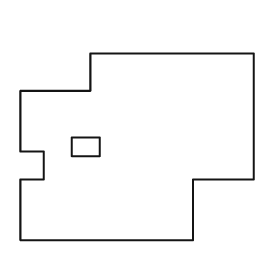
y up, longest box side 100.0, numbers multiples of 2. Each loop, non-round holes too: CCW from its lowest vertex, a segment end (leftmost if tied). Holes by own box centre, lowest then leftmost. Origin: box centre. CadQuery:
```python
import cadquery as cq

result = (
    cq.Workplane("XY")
    .moveTo(-50.0, -40.0)
    .lineTo(24.0, -40.0)
    .lineTo(24.0, -14.0)
    .lineTo(50.0, -14.0)
    .lineTo(50.0, 40.0)
    .lineTo(-20.0, 40.0)
    .lineTo(-20.0, 24.0)
    .lineTo(-50.0, 24.0)
    .lineTo(-50.0, -2.0)
    .lineTo(-40.0, -2.0)
    .lineTo(-40.0, -14.0)
    .lineTo(-50.0, -14.0)
    .close()
    .moveTo(-28.0, -4.0)
    .lineTo(-16.0, -4.0)
    .lineTo(-16.0, 4.0)
    .lineTo(-28.0, 4.0)
    .close()
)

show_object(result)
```